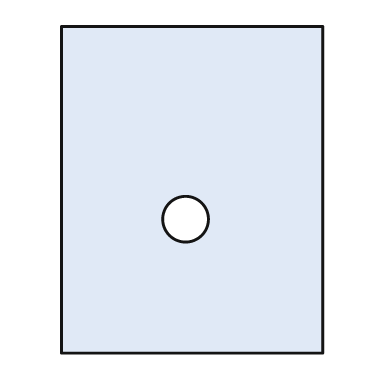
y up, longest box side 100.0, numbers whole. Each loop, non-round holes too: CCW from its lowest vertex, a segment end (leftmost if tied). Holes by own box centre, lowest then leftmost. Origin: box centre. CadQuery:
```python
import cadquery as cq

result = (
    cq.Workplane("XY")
    .moveTo(-40.0, -50.0)
    .lineTo(40.0, -50.0)
    .lineTo(40.0, 50.0)
    .lineTo(-40.0, 50.0)
    .close()
    .moveTo(-2.0, -9.0)
    .circle(7.0)
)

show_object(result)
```